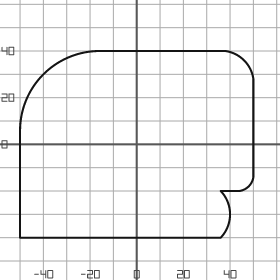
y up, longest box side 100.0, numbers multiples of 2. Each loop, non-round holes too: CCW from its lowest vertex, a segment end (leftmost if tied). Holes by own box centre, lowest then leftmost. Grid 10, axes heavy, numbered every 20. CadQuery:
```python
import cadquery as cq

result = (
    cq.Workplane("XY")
    .moveTo(-50.0, -40.0)
    .lineTo(36.0, -40.0)
    .threePointArc((40.0, -30.0), (36.0, -20.0))
    .lineTo(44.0, -20.0)
    .threePointArc((48.0, -18.0), (50.0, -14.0))
    .lineTo(50.0, 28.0)
    .threePointArc((46.0, 36.0), (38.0, 40.0))
    .lineTo(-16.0, 40.0)
    .threePointArc((-40.0, 30.0), (-50.0, 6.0))
    .close()
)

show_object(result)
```